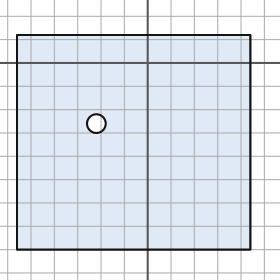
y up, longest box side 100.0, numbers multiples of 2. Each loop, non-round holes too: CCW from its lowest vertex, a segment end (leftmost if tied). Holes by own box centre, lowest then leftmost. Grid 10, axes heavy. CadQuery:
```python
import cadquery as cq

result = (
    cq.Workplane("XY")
    .moveTo(-56.0, -80.0)
    .lineTo(44.0, -80.0)
    .lineTo(44.0, 12.0)
    .lineTo(-56.0, 12.0)
    .close()
    .moveTo(-22.0, -26.0)
    .circle(4.0)
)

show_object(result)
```